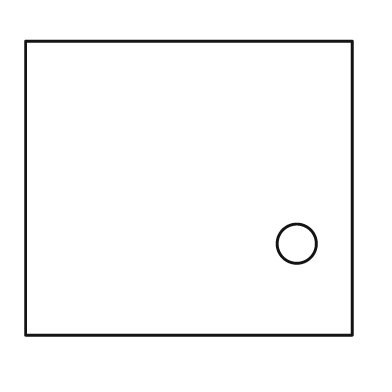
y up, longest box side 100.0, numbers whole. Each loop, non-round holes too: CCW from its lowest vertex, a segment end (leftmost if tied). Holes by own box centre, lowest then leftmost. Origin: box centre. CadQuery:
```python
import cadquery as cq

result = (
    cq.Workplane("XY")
    .moveTo(-50.0, -45.0)
    .lineTo(50.0, -45.0)
    .lineTo(50.0, 45.0)
    .lineTo(-50.0, 45.0)
    .close()
    .moveTo(33.0, -17.0)
    .circle(6.0)
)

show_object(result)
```